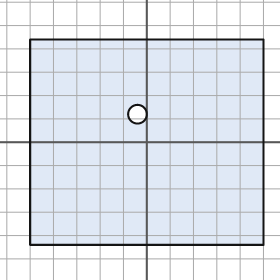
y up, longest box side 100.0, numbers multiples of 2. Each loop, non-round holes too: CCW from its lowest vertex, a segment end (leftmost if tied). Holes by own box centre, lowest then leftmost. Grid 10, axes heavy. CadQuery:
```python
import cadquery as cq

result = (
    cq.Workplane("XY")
    .moveTo(-50.0, -44.0)
    .lineTo(50.0, -44.0)
    .lineTo(50.0, 44.0)
    .lineTo(-50.0, 44.0)
    .close()
    .moveTo(-4.0, 12.0)
    .circle(4.0)
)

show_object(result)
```